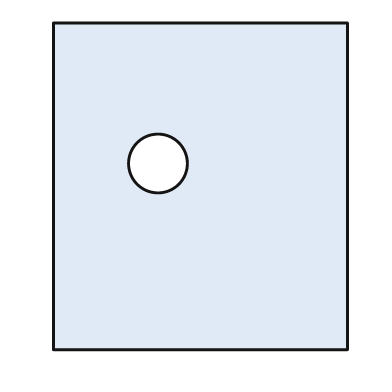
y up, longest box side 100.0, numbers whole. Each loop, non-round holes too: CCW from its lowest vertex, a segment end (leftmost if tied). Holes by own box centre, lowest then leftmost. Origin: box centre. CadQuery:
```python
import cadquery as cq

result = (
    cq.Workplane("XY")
    .moveTo(-45.0, -50.0)
    .lineTo(45.0, -50.0)
    .lineTo(45.0, 50.0)
    .lineTo(-45.0, 50.0)
    .close()
    .moveTo(-13.0, 7.0)
    .circle(9.0)
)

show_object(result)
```